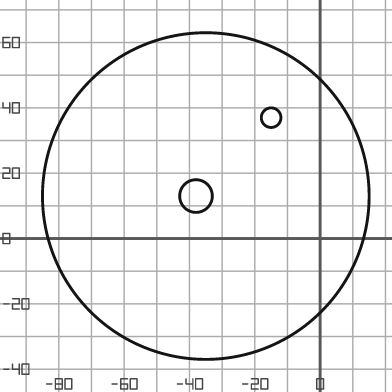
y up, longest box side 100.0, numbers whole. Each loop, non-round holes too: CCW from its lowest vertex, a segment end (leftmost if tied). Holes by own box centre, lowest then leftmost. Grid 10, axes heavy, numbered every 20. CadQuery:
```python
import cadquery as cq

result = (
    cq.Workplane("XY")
    .moveTo(-35.0, 13.0)
    .circle(50.0)
    .moveTo(-38.0, 13.0)
    .circle(5.0)
    .moveTo(-15.0, 37.0)
    .circle(3.0)
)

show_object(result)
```